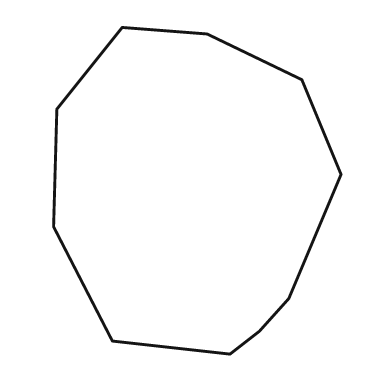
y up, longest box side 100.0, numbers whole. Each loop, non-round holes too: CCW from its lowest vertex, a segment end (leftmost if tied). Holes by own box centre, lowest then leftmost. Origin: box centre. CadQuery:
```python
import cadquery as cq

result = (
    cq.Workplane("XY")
    .moveTo(10.0, -50.0)
    .lineTo(19.0, -43.0)
    .lineTo(28.0, -33.0)
    .lineTo(44.0, 5.0)
    .lineTo(32.0, 34.0)
    .lineTo(3.0, 48.0)
    .lineTo(-23.0, 50.0)
    .lineTo(-43.0, 25.0)
    .lineTo(-44.0, -11.0)
    .lineTo(-26.0, -46.0)
    .close()
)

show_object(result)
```